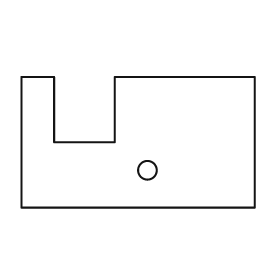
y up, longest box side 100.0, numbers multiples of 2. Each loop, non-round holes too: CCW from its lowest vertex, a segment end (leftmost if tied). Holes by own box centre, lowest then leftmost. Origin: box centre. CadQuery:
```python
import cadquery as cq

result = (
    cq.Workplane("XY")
    .moveTo(-50.0, -28.0)
    .lineTo(50.0, -28.0)
    .lineTo(50.0, 28.0)
    .lineTo(-10.0, 28.0)
    .lineTo(-10.0, 0.0)
    .lineTo(-36.0, 0.0)
    .lineTo(-36.0, 28.0)
    .lineTo(-50.0, 28.0)
    .close()
    .moveTo(4.0, -12.0)
    .circle(4.0)
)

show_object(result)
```